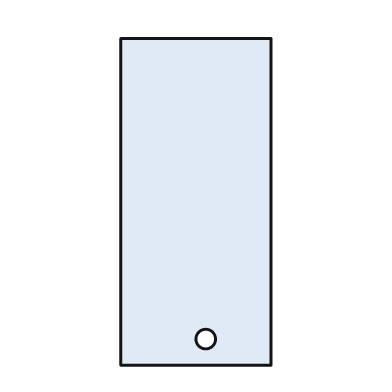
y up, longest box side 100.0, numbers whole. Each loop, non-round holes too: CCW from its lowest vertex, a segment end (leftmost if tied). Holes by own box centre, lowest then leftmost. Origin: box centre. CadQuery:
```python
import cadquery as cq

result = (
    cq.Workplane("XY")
    .moveTo(-23.0, -50.0)
    .lineTo(23.0, -50.0)
    .lineTo(23.0, 50.0)
    .lineTo(-23.0, 50.0)
    .close()
    .moveTo(3.0, -42.0)
    .circle(3.0)
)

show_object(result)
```